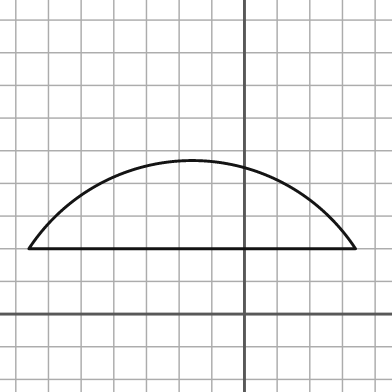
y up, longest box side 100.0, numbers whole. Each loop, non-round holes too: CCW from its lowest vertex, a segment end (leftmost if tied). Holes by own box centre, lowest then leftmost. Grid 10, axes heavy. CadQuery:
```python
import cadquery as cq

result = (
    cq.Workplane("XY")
    .moveTo(-66.0, 20.0)
    .lineTo(34.0, 20.0)
    .threePointArc((-16.0, 47.0), (-66.0, 20.0))
    .close()
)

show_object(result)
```